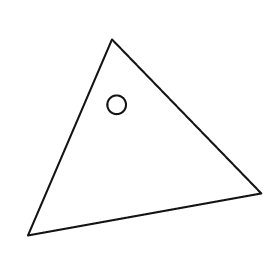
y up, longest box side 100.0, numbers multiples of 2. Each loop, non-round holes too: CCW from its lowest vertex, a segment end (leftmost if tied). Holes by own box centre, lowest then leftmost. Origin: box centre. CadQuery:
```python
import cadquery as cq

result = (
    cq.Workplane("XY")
    .moveTo(-50.0, -42.0)
    .lineTo(50.0, -24.0)
    .lineTo(-14.0, 42.0)
    .close()
    .moveTo(-12.0, 14.0)
    .circle(4.0)
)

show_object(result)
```